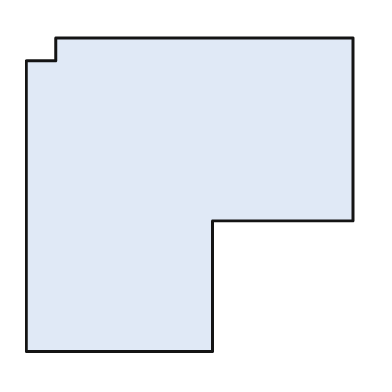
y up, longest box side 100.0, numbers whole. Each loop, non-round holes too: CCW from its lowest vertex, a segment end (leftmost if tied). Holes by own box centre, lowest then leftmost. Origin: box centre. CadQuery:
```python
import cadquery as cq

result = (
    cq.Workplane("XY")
    .moveTo(-50.0, -48.0)
    .lineTo(7.0, -48.0)
    .lineTo(7.0, -8.0)
    .lineTo(50.0, -8.0)
    .lineTo(50.0, 48.0)
    .lineTo(-41.0, 48.0)
    .lineTo(-41.0, 41.0)
    .lineTo(-50.0, 41.0)
    .close()
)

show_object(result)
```